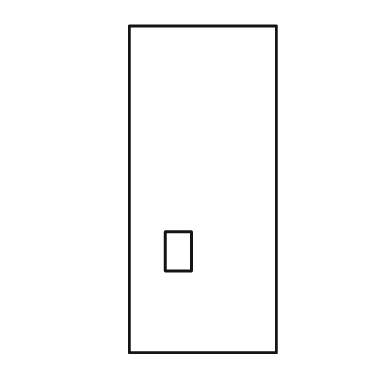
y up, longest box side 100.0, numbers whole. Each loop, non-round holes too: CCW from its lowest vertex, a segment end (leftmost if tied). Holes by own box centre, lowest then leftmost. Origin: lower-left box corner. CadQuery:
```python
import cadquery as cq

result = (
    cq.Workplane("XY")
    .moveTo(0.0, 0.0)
    .lineTo(45.0, 0.0)
    .lineTo(45.0, 100.0)
    .lineTo(0.0, 100.0)
    .close()
    .moveTo(11.0, 25.0)
    .lineTo(19.0, 25.0)
    .lineTo(19.0, 37.0)
    .lineTo(11.0, 37.0)
    .close()
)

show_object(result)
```